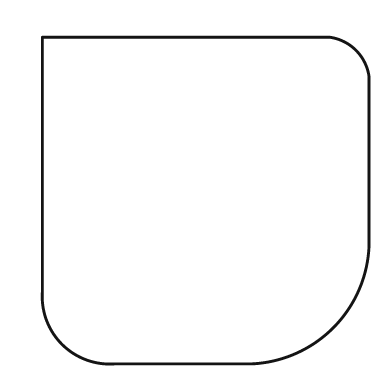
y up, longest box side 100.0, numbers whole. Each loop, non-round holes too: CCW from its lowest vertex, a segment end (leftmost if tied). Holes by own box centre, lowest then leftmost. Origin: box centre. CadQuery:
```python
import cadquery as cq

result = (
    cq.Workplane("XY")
    .moveTo(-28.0, -50.0)
    .lineTo(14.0, -50.0)
    .threePointArc((39.0, -39.0), (50.0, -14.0))
    .lineTo(50.0, 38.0)
    .threePointArc((46.0, 46.0), (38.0, 50.0))
    .lineTo(-50.0, 50.0)
    .lineTo(-50.0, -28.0)
    .threePointArc((-44.0, -44.0), (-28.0, -50.0))
    .close()
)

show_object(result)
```